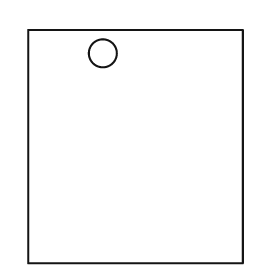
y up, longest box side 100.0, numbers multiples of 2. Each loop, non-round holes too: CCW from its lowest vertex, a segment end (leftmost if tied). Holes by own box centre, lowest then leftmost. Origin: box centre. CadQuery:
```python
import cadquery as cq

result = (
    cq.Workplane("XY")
    .moveTo(-46.0, -50.0)
    .lineTo(46.0, -50.0)
    .lineTo(46.0, 50.0)
    .lineTo(-46.0, 50.0)
    .close()
    .moveTo(-14.0, 40.0)
    .circle(6.0)
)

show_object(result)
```